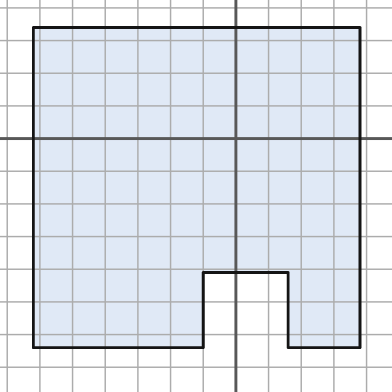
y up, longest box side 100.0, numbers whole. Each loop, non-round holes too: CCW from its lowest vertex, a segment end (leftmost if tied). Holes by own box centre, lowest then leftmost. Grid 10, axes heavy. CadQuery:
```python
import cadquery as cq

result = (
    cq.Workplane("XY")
    .moveTo(-62.0, -64.0)
    .lineTo(-10.0, -64.0)
    .lineTo(-10.0, -41.0)
    .lineTo(16.0, -41.0)
    .lineTo(16.0, -64.0)
    .lineTo(38.0, -64.0)
    .lineTo(38.0, 34.0)
    .lineTo(-62.0, 34.0)
    .close()
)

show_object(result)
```